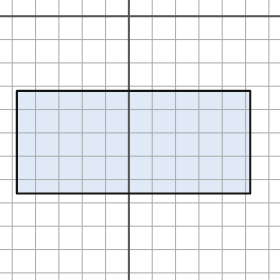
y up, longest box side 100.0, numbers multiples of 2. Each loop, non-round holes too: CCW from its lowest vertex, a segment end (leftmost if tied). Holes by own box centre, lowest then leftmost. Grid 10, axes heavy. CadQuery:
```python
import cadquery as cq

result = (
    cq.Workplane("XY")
    .moveTo(-48.0, -76.0)
    .lineTo(52.0, -76.0)
    .lineTo(52.0, -32.0)
    .lineTo(-48.0, -32.0)
    .close()
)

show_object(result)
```